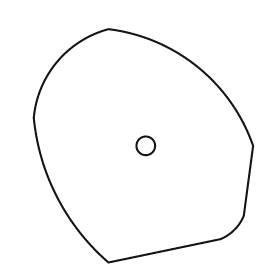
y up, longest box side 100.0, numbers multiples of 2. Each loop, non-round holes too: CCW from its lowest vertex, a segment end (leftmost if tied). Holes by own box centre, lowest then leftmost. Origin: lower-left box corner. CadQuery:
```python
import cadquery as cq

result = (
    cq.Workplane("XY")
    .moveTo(32.0, 0.0)
    .lineTo(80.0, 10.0)
    .threePointArc((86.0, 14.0), (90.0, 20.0))
    .lineTo(94.0, 50.0)
    .threePointArc((70.0, 84.0), (32.0, 100.0))
    .threePointArc((10.0, 86.0), (0.0, 62.0))
    .threePointArc((10.0, 28.0), (32.0, 0.0))
    .close()
    .moveTo(48.0, 50.0)
    .circle(4.0)
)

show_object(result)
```